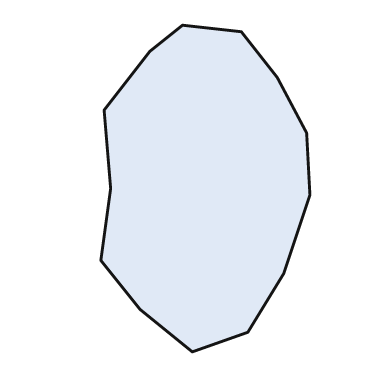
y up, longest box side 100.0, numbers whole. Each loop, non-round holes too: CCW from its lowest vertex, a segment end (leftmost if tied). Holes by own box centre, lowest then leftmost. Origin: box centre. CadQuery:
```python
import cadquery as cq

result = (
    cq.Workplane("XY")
    .moveTo(-4.0, -50.0)
    .lineTo(13.0, -44.0)
    .lineTo(24.0, -26.0)
    .lineTo(32.0, -2.0)
    .lineTo(31.0, 17.0)
    .lineTo(22.0, 34.0)
    .lineTo(11.0, 48.0)
    .lineTo(-7.0, 50.0)
    .lineTo(-17.0, 42.0)
    .lineTo(-31.0, 24.0)
    .lineTo(-29.0, 0.0)
    .lineTo(-32.0, -22.0)
    .lineTo(-20.0, -37.0)
    .close()
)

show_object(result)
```